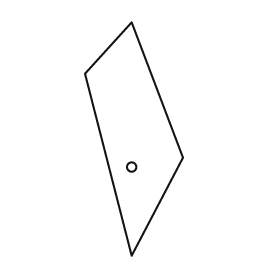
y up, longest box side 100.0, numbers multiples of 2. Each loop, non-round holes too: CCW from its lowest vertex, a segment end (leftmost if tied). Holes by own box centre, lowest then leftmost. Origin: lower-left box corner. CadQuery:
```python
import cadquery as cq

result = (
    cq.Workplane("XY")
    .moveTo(20.0, 0.0)
    .lineTo(42.0, 42.0)
    .lineTo(20.0, 100.0)
    .lineTo(0.0, 78.0)
    .close()
    .moveTo(20.0, 38.0)
    .circle(2.0)
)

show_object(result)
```